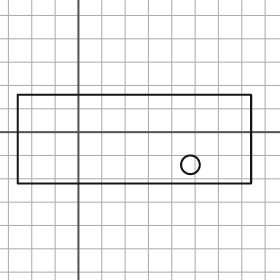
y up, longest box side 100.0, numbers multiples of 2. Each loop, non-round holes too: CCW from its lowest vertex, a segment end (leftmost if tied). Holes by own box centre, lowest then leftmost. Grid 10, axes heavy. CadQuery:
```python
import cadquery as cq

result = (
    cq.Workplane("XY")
    .moveTo(-26.0, -22.0)
    .lineTo(74.0, -22.0)
    .lineTo(74.0, 16.0)
    .lineTo(-26.0, 16.0)
    .close()
    .moveTo(48.0, -14.0)
    .circle(4.0)
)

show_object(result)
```